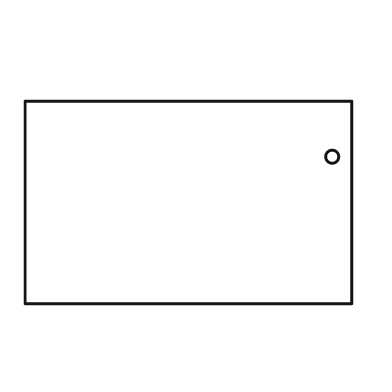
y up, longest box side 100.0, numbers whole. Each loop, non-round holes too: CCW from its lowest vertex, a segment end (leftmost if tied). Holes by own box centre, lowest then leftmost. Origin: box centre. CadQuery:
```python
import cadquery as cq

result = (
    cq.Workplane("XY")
    .moveTo(-50.0, -31.0)
    .lineTo(50.0, -31.0)
    .lineTo(50.0, 31.0)
    .lineTo(-50.0, 31.0)
    .close()
    .moveTo(44.0, 14.0)
    .circle(2.0)
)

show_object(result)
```